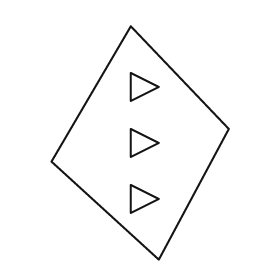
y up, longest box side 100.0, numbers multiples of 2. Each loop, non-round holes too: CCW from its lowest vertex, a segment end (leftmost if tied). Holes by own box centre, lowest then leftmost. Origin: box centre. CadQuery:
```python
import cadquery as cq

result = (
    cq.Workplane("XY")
    .moveTo(8.0, -50.0)
    .lineTo(38.0, 6.0)
    .lineTo(-4.0, 50.0)
    .lineTo(-38.0, -8.0)
    .close()
    .moveTo(-4.0, -30.0)
    .lineTo(8.0, -24.0)
    .lineTo(-4.0, -18.0)
    .close()
    .moveTo(-4.0, -6.0)
    .lineTo(8.0, 0.0)
    .lineTo(-4.0, 6.0)
    .close()
    .moveTo(-4.0, 18.0)
    .lineTo(8.0, 24.0)
    .lineTo(-4.0, 30.0)
    .close()
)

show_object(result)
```